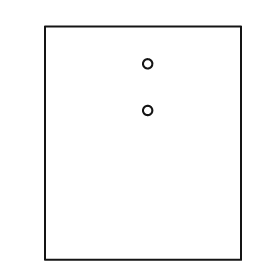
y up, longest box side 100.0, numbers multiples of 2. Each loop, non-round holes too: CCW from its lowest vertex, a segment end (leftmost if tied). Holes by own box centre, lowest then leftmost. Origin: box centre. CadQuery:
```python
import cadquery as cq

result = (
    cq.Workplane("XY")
    .moveTo(-42.0, -50.0)
    .lineTo(42.0, -50.0)
    .lineTo(42.0, 50.0)
    .lineTo(-42.0, 50.0)
    .close()
    .moveTo(2.0, 14.0)
    .circle(2.0)
    .moveTo(2.0, 34.0)
    .circle(2.0)
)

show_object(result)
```